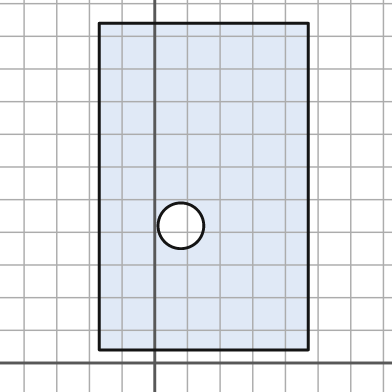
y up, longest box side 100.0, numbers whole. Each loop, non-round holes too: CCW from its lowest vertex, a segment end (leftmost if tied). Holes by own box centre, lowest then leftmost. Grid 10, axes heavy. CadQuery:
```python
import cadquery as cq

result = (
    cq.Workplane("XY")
    .moveTo(-17.0, 4.0)
    .lineTo(47.0, 4.0)
    .lineTo(47.0, 104.0)
    .lineTo(-17.0, 104.0)
    .close()
    .moveTo(8.0, 42.0)
    .circle(7.0)
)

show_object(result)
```